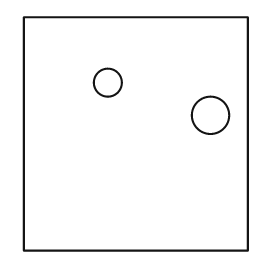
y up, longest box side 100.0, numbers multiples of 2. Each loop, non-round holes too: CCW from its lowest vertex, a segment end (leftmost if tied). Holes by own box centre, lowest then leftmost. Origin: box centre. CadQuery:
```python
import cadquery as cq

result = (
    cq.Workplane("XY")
    .moveTo(-48.0, -50.0)
    .lineTo(48.0, -50.0)
    .lineTo(48.0, 50.0)
    .lineTo(-48.0, 50.0)
    .close()
    .moveTo(32.0, 8.0)
    .circle(8.0)
    .moveTo(-12.0, 22.0)
    .circle(6.0)
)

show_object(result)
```